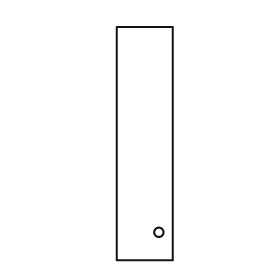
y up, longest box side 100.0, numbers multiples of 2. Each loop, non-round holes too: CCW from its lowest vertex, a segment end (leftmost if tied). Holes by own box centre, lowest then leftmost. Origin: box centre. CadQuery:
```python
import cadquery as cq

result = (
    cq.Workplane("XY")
    .moveTo(-12.0, -50.0)
    .lineTo(12.0, -50.0)
    .lineTo(12.0, 50.0)
    .lineTo(-12.0, 50.0)
    .close()
    .moveTo(6.0, -38.0)
    .circle(2.0)
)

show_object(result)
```